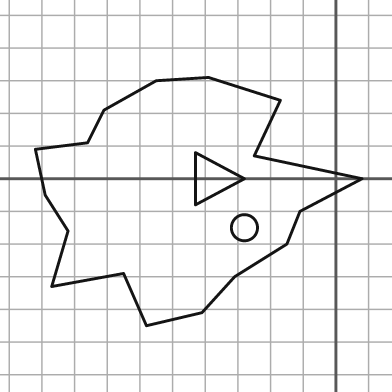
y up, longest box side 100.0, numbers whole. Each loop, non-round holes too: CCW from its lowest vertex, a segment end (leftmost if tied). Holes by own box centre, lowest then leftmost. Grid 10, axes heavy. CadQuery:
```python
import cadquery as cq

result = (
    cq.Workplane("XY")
    .moveTo(-58.0, -45.0)
    .lineTo(-41.0, -41.0)
    .lineTo(-31.0, -30.0)
    .lineTo(-15.0, -20.0)
    .lineTo(-11.0, -10.0)
    .lineTo(8.0, 0.0)
    .lineTo(-25.0, 7.0)
    .lineTo(-17.0, 24.0)
    .lineTo(-39.0, 31.0)
    .lineTo(-55.0, 30.0)
    .lineTo(-71.0, 21.0)
    .lineTo(-76.0, 11.0)
    .lineTo(-92.0, 9.0)
    .lineTo(-89.0, -5.0)
    .lineTo(-82.0, -16.0)
    .lineTo(-87.0, -33.0)
    .lineTo(-65.0, -29.0)
    .close()
    .moveTo(-28.0, -15.0)
    .circle(4.0)
    .moveTo(-43.0, -8.0)
    .lineTo(-28.0, 0.0)
    .lineTo(-43.0, 8.0)
    .close()
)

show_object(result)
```